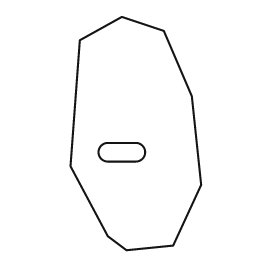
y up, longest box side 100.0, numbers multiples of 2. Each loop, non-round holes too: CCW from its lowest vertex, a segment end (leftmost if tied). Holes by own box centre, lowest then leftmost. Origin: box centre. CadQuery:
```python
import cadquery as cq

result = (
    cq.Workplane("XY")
    .moveTo(-4.0, -50.0)
    .lineTo(16.0, -48.0)
    .lineTo(28.0, -22.0)
    .lineTo(24.0, 16.0)
    .lineTo(12.0, 44.0)
    .lineTo(-6.0, 50.0)
    .lineTo(-24.0, 40.0)
    .lineTo(-28.0, -14.0)
    .lineTo(-12.0, -44.0)
    .close()
    .moveTo(-12.0, -12.0)
    .lineTo(0.0, -12.0)
    .threePointArc((4.0, -8.0), (0.0, -4.0))
    .lineTo(-12.0, -4.0)
    .threePointArc((-16.0, -8.0), (-12.0, -12.0))
    .close()
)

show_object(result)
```